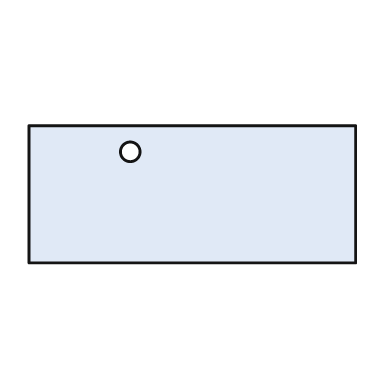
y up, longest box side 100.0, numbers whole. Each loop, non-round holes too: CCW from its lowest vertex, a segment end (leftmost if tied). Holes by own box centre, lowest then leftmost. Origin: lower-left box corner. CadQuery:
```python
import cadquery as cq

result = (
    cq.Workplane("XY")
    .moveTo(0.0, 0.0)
    .lineTo(100.0, 0.0)
    .lineTo(100.0, 42.0)
    .lineTo(0.0, 42.0)
    .close()
    .moveTo(31.0, 34.0)
    .circle(3.0)
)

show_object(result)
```